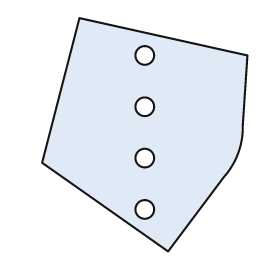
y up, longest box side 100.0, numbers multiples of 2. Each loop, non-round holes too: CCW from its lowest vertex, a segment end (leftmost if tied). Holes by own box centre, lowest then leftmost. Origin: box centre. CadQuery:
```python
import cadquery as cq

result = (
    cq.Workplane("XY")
    .moveTo(10.0, -50.0)
    .lineTo(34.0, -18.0)
    .threePointArc((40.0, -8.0), (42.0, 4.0))
    .lineTo(44.0, 34.0)
    .lineTo(-28.0, 50.0)
    .lineTo(-44.0, -12.0)
    .close()
    .moveTo(0.0, -32.0)
    .circle(4.0)
    .moveTo(0.0, -10.0)
    .circle(4.0)
    .moveTo(0.0, 12.0)
    .circle(4.0)
    .moveTo(0.0, 34.0)
    .circle(4.0)
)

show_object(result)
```